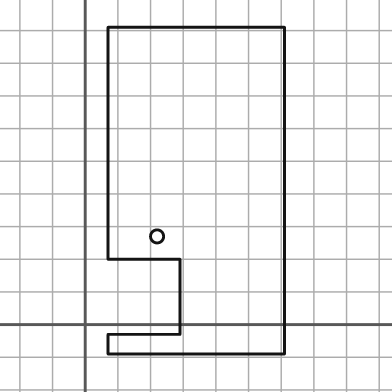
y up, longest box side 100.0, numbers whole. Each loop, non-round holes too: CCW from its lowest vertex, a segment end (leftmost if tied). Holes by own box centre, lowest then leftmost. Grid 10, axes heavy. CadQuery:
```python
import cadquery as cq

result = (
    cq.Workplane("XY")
    .moveTo(7.0, -9.0)
    .lineTo(61.0, -9.0)
    .lineTo(61.0, 91.0)
    .lineTo(7.0, 91.0)
    .lineTo(7.0, 20.0)
    .lineTo(29.0, 20.0)
    .lineTo(29.0, -3.0)
    .lineTo(7.0, -3.0)
    .close()
    .moveTo(22.0, 27.0)
    .circle(2.0)
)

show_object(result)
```